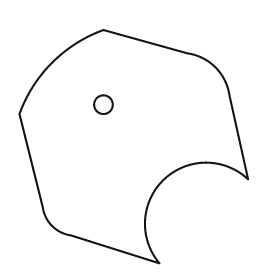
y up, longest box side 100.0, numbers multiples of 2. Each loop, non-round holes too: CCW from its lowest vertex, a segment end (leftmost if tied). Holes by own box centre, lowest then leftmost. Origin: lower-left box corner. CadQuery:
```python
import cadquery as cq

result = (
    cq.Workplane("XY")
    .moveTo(60.0, 0.0)
    .threePointArc((62.0, 36.0), (98.0, 36.0))
    .lineTo(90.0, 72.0)
    .threePointArc((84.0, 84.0), (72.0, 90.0))
    .lineTo(36.0, 100.0)
    .threePointArc((14.0, 86.0), (0.0, 64.0))
    .lineTo(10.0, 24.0)
    .threePointArc((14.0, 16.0), (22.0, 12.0))
    .close()
    .moveTo(36.0, 68.0)
    .circle(4.0)
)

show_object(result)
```